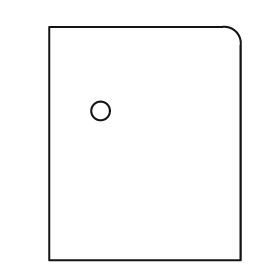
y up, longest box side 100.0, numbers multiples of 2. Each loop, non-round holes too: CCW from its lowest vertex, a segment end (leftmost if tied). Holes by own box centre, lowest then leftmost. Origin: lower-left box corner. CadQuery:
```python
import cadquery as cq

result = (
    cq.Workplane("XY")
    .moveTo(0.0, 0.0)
    .lineTo(82.0, 0.0)
    .lineTo(82.0, 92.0)
    .threePointArc((80.0, 98.0), (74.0, 100.0))
    .lineTo(0.0, 100.0)
    .close()
    .moveTo(22.0, 64.0)
    .circle(4.0)
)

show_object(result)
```